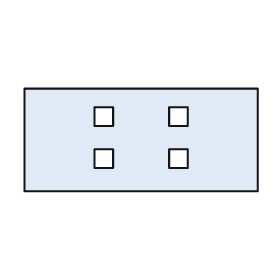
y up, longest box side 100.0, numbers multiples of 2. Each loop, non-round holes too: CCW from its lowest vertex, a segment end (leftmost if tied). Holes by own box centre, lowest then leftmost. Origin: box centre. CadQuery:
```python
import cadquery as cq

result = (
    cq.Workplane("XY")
    .moveTo(-50.0, -22.0)
    .lineTo(50.0, -22.0)
    .lineTo(50.0, 22.0)
    .lineTo(-50.0, 22.0)
    .close()
    .moveTo(-20.0, -12.0)
    .lineTo(-12.0, -12.0)
    .lineTo(-12.0, -4.0)
    .lineTo(-20.0, -4.0)
    .close()
    .moveTo(12.0, -12.0)
    .lineTo(20.0, -12.0)
    .lineTo(20.0, -4.0)
    .lineTo(12.0, -4.0)
    .close()
    .moveTo(-20.0, 6.0)
    .lineTo(-12.0, 6.0)
    .lineTo(-12.0, 14.0)
    .lineTo(-20.0, 14.0)
    .close()
    .moveTo(12.0, 6.0)
    .lineTo(20.0, 6.0)
    .lineTo(20.0, 14.0)
    .lineTo(12.0, 14.0)
    .close()
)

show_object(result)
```